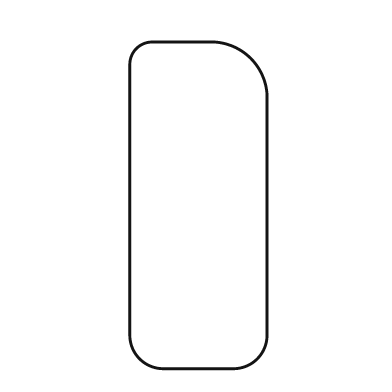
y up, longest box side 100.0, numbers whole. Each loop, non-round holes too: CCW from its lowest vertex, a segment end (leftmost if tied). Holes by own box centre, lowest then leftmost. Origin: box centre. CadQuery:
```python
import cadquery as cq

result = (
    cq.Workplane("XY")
    .moveTo(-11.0, -50.0)
    .lineTo(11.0, -50.0)
    .threePointArc((18.0, -47.0), (21.0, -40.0))
    .lineTo(21.0, 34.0)
    .threePointArc((16.0, 45.0), (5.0, 50.0))
    .lineTo(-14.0, 50.0)
    .threePointArc((-19.0, 48.0), (-21.0, 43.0))
    .lineTo(-21.0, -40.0)
    .threePointArc((-18.0, -47.0), (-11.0, -50.0))
    .close()
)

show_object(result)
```